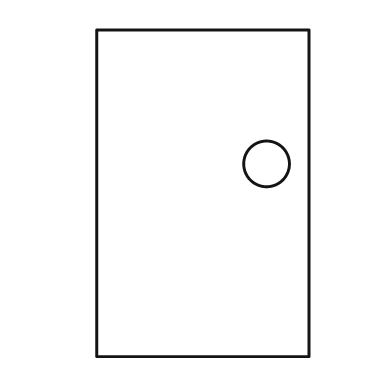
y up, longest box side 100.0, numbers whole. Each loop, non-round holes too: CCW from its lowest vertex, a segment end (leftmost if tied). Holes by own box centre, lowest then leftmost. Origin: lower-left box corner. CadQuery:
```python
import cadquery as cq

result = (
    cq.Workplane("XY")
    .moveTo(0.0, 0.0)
    .lineTo(65.0, 0.0)
    .lineTo(65.0, 100.0)
    .lineTo(0.0, 100.0)
    .close()
    .moveTo(52.0, 59.0)
    .circle(7.0)
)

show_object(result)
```